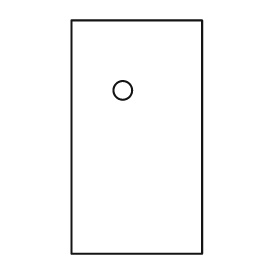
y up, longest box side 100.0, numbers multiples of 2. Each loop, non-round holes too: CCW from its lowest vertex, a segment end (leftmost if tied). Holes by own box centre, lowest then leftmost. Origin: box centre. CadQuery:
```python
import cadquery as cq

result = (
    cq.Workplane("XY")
    .moveTo(-28.0, -50.0)
    .lineTo(28.0, -50.0)
    .lineTo(28.0, 50.0)
    .lineTo(-28.0, 50.0)
    .close()
    .moveTo(-6.0, 20.0)
    .circle(4.0)
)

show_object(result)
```